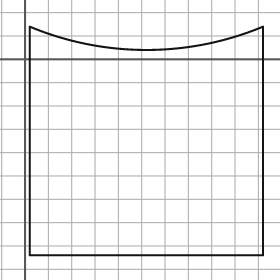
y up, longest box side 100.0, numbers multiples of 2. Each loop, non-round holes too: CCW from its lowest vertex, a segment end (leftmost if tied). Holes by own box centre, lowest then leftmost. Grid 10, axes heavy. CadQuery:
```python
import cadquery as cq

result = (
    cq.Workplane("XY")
    .moveTo(2.0, -84.0)
    .lineTo(102.0, -84.0)
    .lineTo(102.0, 14.0)
    .threePointArc((52.0, 4.0), (2.0, 14.0))
    .close()
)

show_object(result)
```